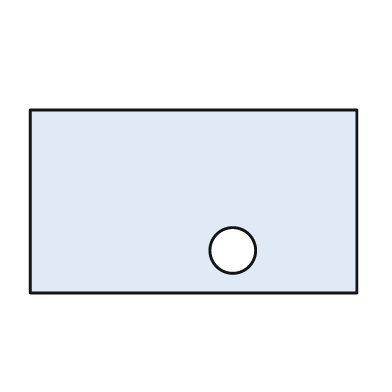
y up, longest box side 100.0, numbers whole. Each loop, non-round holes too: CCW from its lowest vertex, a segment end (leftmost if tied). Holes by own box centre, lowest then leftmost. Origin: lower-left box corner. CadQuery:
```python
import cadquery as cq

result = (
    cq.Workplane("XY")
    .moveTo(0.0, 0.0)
    .lineTo(100.0, 0.0)
    .lineTo(100.0, 56.0)
    .lineTo(0.0, 56.0)
    .close()
    .moveTo(62.0, 13.0)
    .circle(7.0)
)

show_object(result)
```